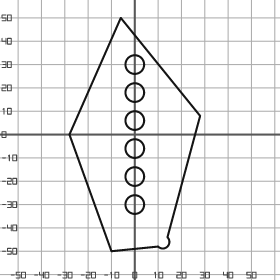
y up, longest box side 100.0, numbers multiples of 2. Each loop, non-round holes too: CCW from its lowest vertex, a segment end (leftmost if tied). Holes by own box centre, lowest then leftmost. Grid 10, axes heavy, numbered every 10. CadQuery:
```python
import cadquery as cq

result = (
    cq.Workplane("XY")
    .moveTo(-10.0, -50.0)
    .lineTo(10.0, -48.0)
    .threePointArc((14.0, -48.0), (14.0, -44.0))
    .lineTo(28.0, 8.0)
    .lineTo(-6.0, 50.0)
    .lineTo(-28.0, 0.0)
    .close()
    .moveTo(0.0, -30.0)
    .circle(4.0)
    .moveTo(0.0, -18.0)
    .circle(4.0)
    .moveTo(0.0, -6.0)
    .circle(4.0)
    .moveTo(0.0, 6.0)
    .circle(4.0)
    .moveTo(0.0, 18.0)
    .circle(4.0)
    .moveTo(0.0, 30.0)
    .circle(4.0)
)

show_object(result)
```